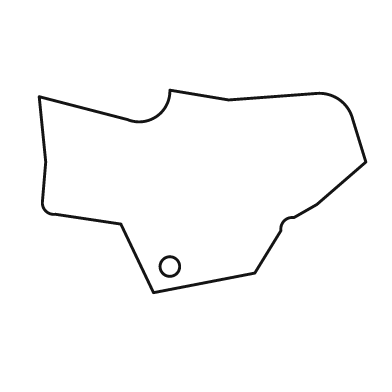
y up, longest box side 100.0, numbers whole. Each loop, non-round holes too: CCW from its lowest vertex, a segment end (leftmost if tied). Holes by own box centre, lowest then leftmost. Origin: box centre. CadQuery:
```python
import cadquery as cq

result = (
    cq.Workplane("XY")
    .moveTo(-15.0, -31.0)
    .lineTo(16.0, -25.0)
    .lineTo(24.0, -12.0)
    .threePointArc((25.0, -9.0), (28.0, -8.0))
    .lineTo(35.0, -4.0)
    .lineTo(50.0, 9.0)
    .lineTo(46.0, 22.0)
    .threePointArc((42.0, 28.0), (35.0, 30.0))
    .lineTo(8.0, 28.0)
    .lineTo(-10.0, 31.0)
    .threePointArc((-14.0, 23.0), (-23.0, 22.0))
    .lineTo(-50.0, 29.0)
    .lineTo(-48.0, 9.0)
    .lineTo(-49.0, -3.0)
    .threePointArc((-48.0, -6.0), (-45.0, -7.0))
    .lineTo(-25.0, -10.0)
    .close()
    .moveTo(-10.0, -23.0)
    .circle(3.0)
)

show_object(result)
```